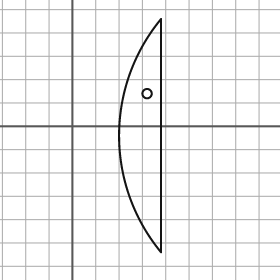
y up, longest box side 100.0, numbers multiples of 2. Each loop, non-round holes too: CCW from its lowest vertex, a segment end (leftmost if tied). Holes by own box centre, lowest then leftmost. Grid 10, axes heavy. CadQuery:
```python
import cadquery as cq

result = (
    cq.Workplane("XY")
    .moveTo(38.0, -54.0)
    .lineTo(38.0, 46.0)
    .threePointArc((20.0, -4.0), (38.0, -54.0))
    .close()
    .moveTo(32.0, 14.0)
    .circle(2.0)
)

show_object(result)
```